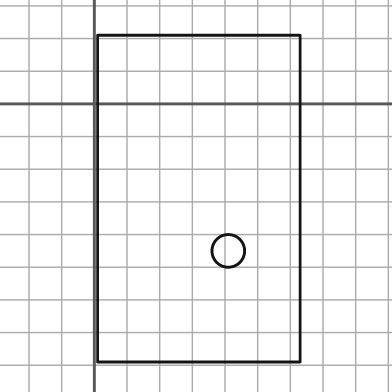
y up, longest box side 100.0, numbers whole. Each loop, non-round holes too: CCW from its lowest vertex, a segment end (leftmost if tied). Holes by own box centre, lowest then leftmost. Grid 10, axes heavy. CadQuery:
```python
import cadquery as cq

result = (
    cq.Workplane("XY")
    .moveTo(1.0, -79.0)
    .lineTo(63.0, -79.0)
    .lineTo(63.0, 21.0)
    .lineTo(1.0, 21.0)
    .close()
    .moveTo(41.0, -45.0)
    .circle(5.0)
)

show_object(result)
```